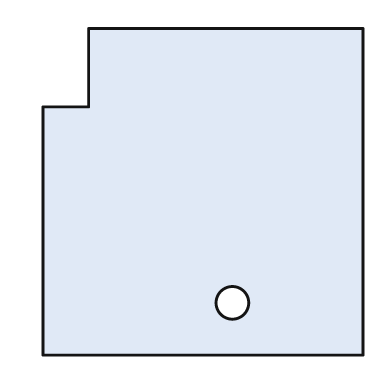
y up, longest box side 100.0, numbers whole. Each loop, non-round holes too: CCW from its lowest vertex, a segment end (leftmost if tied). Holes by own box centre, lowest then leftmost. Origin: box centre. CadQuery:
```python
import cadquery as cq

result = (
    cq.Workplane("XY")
    .moveTo(-49.0, -50.0)
    .lineTo(49.0, -50.0)
    .lineTo(49.0, 50.0)
    .lineTo(-35.0, 50.0)
    .lineTo(-35.0, 26.0)
    .lineTo(-49.0, 26.0)
    .close()
    .moveTo(9.0, -34.0)
    .circle(5.0)
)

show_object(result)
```